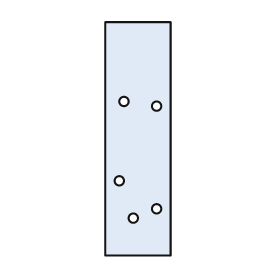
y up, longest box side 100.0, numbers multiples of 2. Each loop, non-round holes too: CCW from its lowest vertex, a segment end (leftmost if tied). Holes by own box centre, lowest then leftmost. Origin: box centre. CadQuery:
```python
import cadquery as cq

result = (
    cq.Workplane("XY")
    .moveTo(-14.0, -50.0)
    .lineTo(14.0, -50.0)
    .lineTo(14.0, 50.0)
    .lineTo(-14.0, 50.0)
    .close()
    .moveTo(-2.0, -34.0)
    .circle(2.0)
    .moveTo(8.0, -30.0)
    .circle(2.0)
    .moveTo(-8.0, -18.0)
    .circle(2.0)
    .moveTo(8.0, 14.0)
    .circle(2.0)
    .moveTo(-6.0, 16.0)
    .circle(2.0)
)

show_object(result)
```